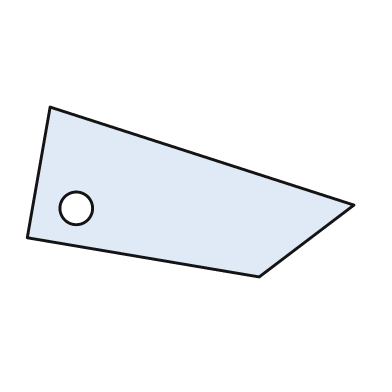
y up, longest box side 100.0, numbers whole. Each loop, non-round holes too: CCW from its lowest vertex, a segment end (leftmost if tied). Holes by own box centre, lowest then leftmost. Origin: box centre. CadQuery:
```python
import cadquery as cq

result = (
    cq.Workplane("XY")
    .moveTo(21.0, -26.0)
    .lineTo(50.0, -4.0)
    .lineTo(-43.0, 26.0)
    .lineTo(-50.0, -14.0)
    .close()
    .moveTo(-35.0, -5.0)
    .circle(5.0)
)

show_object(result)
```